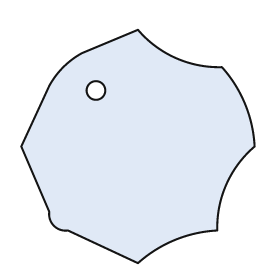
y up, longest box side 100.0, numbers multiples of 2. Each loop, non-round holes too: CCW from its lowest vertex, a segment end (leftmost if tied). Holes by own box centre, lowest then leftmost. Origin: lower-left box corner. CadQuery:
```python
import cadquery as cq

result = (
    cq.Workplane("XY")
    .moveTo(50.0, 0.0)
    .threePointArc((66.0, 10.0), (84.0, 14.0))
    .threePointArc((88.0, 34.0), (100.0, 50.0))
    .threePointArc((96.0, 68.0), (86.0, 84.0))
    .threePointArc((66.0, 88.0), (50.0, 100.0))
    .lineTo(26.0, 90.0)
    .threePointArc((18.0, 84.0), (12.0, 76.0))
    .lineTo(0.0, 50.0)
    .lineTo(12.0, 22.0)
    .threePointArc((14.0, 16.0), (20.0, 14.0))
    .close()
    .moveTo(32.0, 74.0)
    .circle(4.0)
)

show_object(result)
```